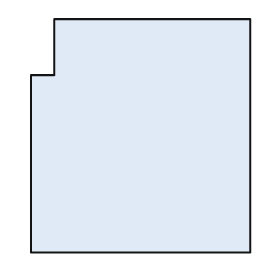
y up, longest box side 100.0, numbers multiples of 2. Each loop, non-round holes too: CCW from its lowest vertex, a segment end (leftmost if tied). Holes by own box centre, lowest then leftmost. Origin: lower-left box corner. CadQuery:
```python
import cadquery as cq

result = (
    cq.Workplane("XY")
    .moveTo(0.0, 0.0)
    .lineTo(94.0, 0.0)
    .lineTo(94.0, 100.0)
    .lineTo(10.0, 100.0)
    .lineTo(10.0, 76.0)
    .lineTo(0.0, 76.0)
    .close()
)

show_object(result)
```